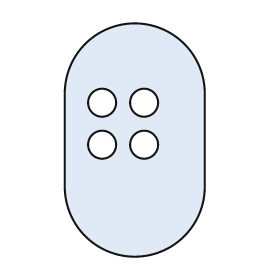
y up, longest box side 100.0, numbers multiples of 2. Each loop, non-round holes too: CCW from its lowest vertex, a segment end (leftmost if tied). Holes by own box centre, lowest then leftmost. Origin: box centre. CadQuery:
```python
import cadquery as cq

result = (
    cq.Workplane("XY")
    .moveTo(-30.0, -20.0)
    .threePointArc((0.0, -50.0), (30.0, -20.0))
    .lineTo(30.0, 20.0)
    .threePointArc((0.0, 50.0), (-30.0, 20.0))
    .close()
    .moveTo(-14.0, -2.0)
    .circle(6.0)
    .moveTo(4.0, -2.0)
    .circle(6.0)
    .moveTo(-14.0, 16.0)
    .circle(6.0)
    .moveTo(4.0, 16.0)
    .circle(6.0)
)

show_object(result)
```